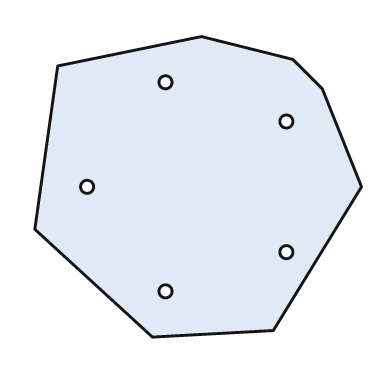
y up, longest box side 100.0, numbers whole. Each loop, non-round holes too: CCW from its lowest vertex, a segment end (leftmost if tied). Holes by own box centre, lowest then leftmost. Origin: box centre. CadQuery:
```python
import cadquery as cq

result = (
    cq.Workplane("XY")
    .moveTo(-14.0, -46.0)
    .lineTo(23.0, -44.0)
    .lineTo(50.0, 0.0)
    .lineTo(38.0, 30.0)
    .lineTo(29.0, 39.0)
    .lineTo(1.0, 46.0)
    .lineTo(-43.0, 37.0)
    .lineTo(-50.0, -13.0)
    .close()
    .moveTo(-10.0, -32.0)
    .circle(2.0)
    .moveTo(27.0, -20.0)
    .circle(2.0)
    .moveTo(-34.0, 0.0)
    .circle(2.0)
    .moveTo(27.0, 20.0)
    .circle(2.0)
    .moveTo(-10.0, 32.0)
    .circle(2.0)
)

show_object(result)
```